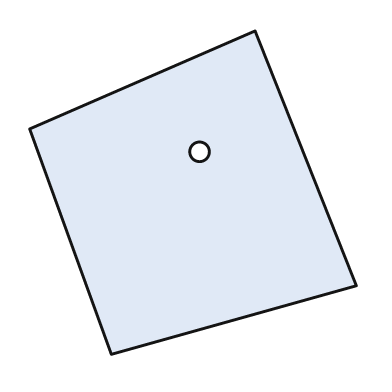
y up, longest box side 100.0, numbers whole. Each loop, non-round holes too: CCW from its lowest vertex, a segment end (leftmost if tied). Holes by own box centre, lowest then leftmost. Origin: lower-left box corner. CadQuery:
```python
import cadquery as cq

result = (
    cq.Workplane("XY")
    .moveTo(25.0, 0.0)
    .lineTo(100.0, 21.0)
    .lineTo(69.0, 99.0)
    .lineTo(0.0, 69.0)
    .close()
    .moveTo(52.0, 62.0)
    .circle(3.0)
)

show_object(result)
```